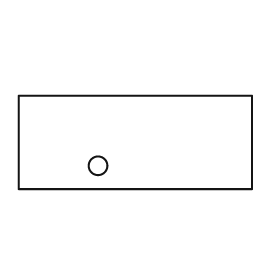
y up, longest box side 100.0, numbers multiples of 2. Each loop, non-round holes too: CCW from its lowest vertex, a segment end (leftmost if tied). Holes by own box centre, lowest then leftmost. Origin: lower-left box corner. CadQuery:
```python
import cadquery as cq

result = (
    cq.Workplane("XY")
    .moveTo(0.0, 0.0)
    .lineTo(100.0, 0.0)
    .lineTo(100.0, 40.0)
    .lineTo(0.0, 40.0)
    .close()
    .moveTo(34.0, 10.0)
    .circle(4.0)
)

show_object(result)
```